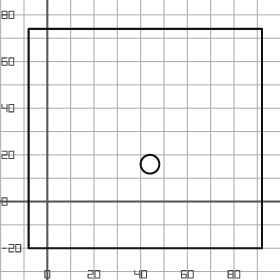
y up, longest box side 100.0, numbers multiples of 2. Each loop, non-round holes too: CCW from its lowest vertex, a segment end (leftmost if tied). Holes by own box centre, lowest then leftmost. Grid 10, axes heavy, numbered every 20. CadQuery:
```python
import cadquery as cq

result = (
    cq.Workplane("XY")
    .moveTo(-8.0, -20.0)
    .lineTo(92.0, -20.0)
    .lineTo(92.0, 74.0)
    .lineTo(-8.0, 74.0)
    .close()
    .moveTo(44.0, 16.0)
    .circle(4.0)
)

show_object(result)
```